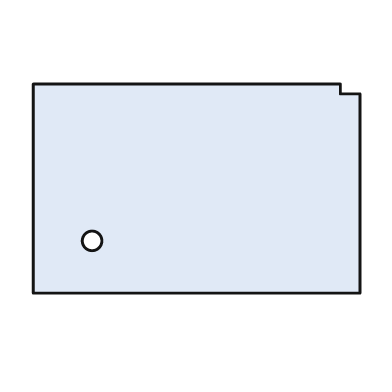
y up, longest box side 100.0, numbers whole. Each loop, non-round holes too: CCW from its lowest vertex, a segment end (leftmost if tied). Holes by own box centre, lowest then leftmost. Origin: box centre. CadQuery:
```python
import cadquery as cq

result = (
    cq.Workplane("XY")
    .moveTo(-50.0, -32.0)
    .lineTo(50.0, -32.0)
    .lineTo(50.0, 29.0)
    .lineTo(44.0, 29.0)
    .lineTo(44.0, 32.0)
    .lineTo(-50.0, 32.0)
    .close()
    .moveTo(-32.0, -16.0)
    .circle(3.0)
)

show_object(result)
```